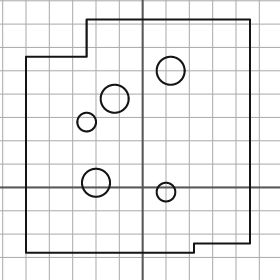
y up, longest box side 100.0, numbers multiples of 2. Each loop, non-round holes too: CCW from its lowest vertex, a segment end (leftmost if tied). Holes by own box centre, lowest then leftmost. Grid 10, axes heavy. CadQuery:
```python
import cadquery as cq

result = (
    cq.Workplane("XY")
    .moveTo(-50.0, -28.0)
    .lineTo(22.0, -28.0)
    .lineTo(22.0, -24.0)
    .lineTo(46.0, -24.0)
    .lineTo(46.0, 72.0)
    .lineTo(-24.0, 72.0)
    .lineTo(-24.0, 56.0)
    .lineTo(-50.0, 56.0)
    .close()
    .moveTo(10.0, -2.0)
    .circle(4.0)
    .moveTo(-20.0, 2.0)
    .circle(6.0)
    .moveTo(-24.0, 28.0)
    .circle(4.0)
    .moveTo(-12.0, 38.0)
    .circle(6.0)
    .moveTo(12.0, 50.0)
    .circle(6.0)
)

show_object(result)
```